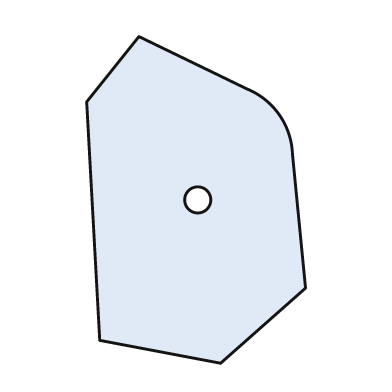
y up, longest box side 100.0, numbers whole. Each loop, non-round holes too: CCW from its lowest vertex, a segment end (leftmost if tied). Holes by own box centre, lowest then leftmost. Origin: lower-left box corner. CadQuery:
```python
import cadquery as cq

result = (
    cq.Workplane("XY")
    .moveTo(41.0, 0.0)
    .lineTo(67.0, 23.0)
    .lineTo(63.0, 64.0)
    .threePointArc((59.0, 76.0), (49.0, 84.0))
    .lineTo(16.0, 100.0)
    .lineTo(0.0, 80.0)
    .lineTo(4.0, 7.0)
    .close()
    .moveTo(34.0, 50.0)
    .circle(4.0)
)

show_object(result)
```